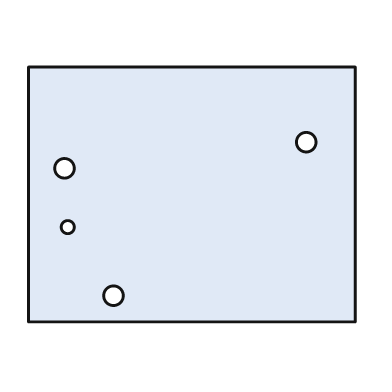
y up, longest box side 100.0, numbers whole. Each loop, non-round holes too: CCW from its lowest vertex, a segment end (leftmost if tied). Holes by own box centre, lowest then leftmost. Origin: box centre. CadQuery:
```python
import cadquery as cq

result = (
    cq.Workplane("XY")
    .moveTo(-50.0, -39.0)
    .lineTo(50.0, -39.0)
    .lineTo(50.0, 39.0)
    .lineTo(-50.0, 39.0)
    .close()
    .moveTo(-24.0, -31.0)
    .circle(3.0)
    .moveTo(-38.0, -10.0)
    .circle(2.0)
    .moveTo(-39.0, 8.0)
    .circle(3.0)
    .moveTo(35.0, 16.0)
    .circle(3.0)
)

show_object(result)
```